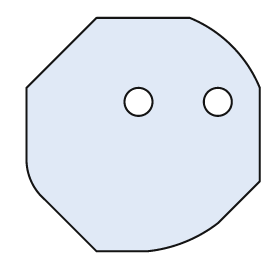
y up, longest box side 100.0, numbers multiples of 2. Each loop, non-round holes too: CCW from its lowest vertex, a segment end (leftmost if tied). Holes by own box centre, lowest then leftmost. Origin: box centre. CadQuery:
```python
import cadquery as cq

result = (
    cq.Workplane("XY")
    .moveTo(-20.0, -50.0)
    .lineTo(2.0, -50.0)
    .threePointArc((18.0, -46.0), (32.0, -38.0))
    .lineTo(50.0, -20.0)
    .lineTo(50.0, 20.0)
    .threePointArc((38.0, 38.0), (20.0, 50.0))
    .lineTo(-20.0, 50.0)
    .lineTo(-50.0, 20.0)
    .lineTo(-50.0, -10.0)
    .threePointArc((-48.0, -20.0), (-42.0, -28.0))
    .close()
    .moveTo(-2.0, 14.0)
    .circle(6.0)
    .moveTo(32.0, 14.0)
    .circle(6.0)
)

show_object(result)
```